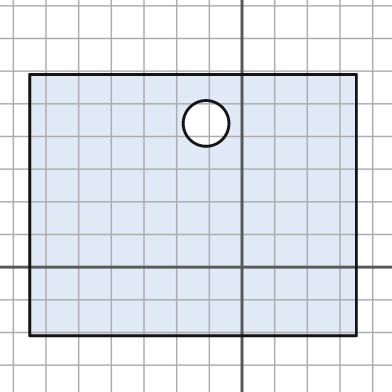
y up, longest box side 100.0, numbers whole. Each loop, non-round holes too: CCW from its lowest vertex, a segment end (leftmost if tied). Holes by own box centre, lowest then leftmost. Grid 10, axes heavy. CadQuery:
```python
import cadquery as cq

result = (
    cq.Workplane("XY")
    .moveTo(-65.0, -21.0)
    .lineTo(35.0, -21.0)
    .lineTo(35.0, 59.0)
    .lineTo(-65.0, 59.0)
    .close()
    .moveTo(-11.0, 44.0)
    .circle(7.0)
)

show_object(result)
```